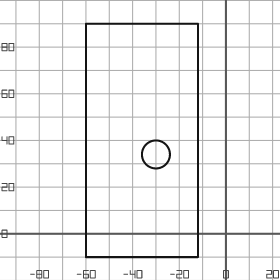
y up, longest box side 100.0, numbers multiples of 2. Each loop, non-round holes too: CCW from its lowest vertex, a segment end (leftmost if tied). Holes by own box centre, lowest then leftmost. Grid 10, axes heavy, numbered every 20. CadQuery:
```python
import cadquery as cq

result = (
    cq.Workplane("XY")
    .moveTo(-60.0, -10.0)
    .lineTo(-12.0, -10.0)
    .lineTo(-12.0, 90.0)
    .lineTo(-60.0, 90.0)
    .close()
    .moveTo(-30.0, 34.0)
    .circle(6.0)
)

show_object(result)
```